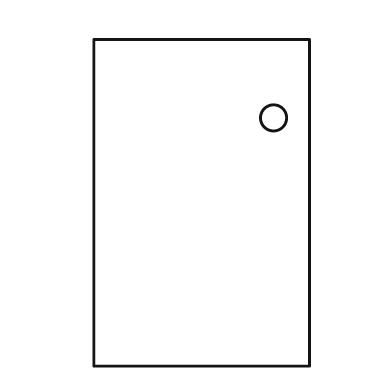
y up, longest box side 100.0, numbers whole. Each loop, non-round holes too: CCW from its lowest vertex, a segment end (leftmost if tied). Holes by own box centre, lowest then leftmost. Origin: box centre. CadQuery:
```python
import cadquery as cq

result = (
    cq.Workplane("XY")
    .moveTo(-33.0, -50.0)
    .lineTo(33.0, -50.0)
    .lineTo(33.0, 50.0)
    .lineTo(-33.0, 50.0)
    .close()
    .moveTo(22.0, 26.0)
    .circle(4.0)
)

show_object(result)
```